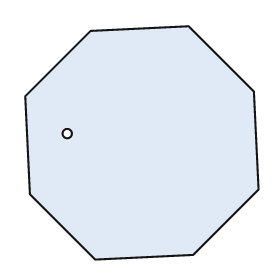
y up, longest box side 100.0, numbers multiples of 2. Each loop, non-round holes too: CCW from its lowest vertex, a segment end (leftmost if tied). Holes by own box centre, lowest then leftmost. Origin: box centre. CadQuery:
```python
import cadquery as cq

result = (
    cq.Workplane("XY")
    .moveTo(-20.0, -50.0)
    .lineTo(22.0, -48.0)
    .lineTo(50.0, -20.0)
    .lineTo(48.0, 22.0)
    .lineTo(20.0, 50.0)
    .lineTo(-22.0, 48.0)
    .lineTo(-50.0, 20.0)
    .lineTo(-48.0, -22.0)
    .close()
    .moveTo(-32.0, 4.0)
    .circle(2.0)
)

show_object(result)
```